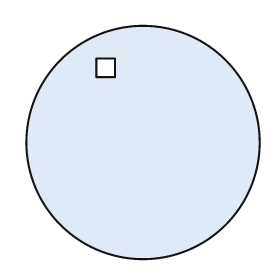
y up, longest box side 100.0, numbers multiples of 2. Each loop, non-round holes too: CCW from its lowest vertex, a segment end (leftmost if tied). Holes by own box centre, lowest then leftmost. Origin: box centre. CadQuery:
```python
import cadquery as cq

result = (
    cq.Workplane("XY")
    .moveTo(0.0, 0.0)
    .circle(50.0)
    .moveTo(-20.0, 28.0)
    .lineTo(-12.0, 28.0)
    .lineTo(-12.0, 36.0)
    .lineTo(-20.0, 36.0)
    .close()
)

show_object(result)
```